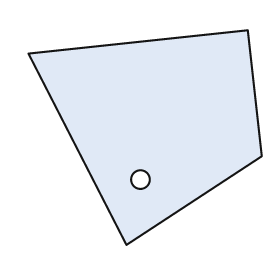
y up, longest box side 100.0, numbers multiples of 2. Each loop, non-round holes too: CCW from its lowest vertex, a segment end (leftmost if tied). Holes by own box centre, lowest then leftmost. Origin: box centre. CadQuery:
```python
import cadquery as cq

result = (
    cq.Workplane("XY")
    .moveTo(-8.0, -46.0)
    .lineTo(50.0, -8.0)
    .lineTo(44.0, 46.0)
    .lineTo(-50.0, 36.0)
    .close()
    .moveTo(-2.0, -18.0)
    .circle(4.0)
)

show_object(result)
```